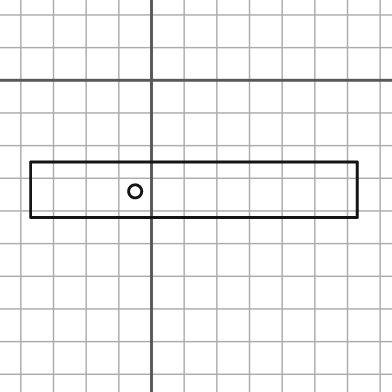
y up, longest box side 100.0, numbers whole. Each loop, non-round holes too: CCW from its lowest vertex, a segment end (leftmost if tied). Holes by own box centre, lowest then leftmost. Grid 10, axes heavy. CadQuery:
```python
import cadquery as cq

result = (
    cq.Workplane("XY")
    .moveTo(-37.0, -42.0)
    .lineTo(63.0, -42.0)
    .lineTo(63.0, -25.0)
    .lineTo(-37.0, -25.0)
    .close()
    .moveTo(-5.0, -34.0)
    .circle(2.0)
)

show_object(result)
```